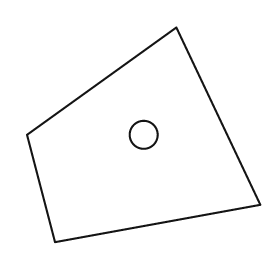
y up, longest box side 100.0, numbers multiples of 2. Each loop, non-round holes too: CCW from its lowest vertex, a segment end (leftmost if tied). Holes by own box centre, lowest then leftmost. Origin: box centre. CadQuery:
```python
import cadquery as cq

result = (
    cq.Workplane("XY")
    .moveTo(-38.0, -46.0)
    .lineTo(50.0, -30.0)
    .lineTo(14.0, 46.0)
    .lineTo(-50.0, 0.0)
    .close()
    .moveTo(0.0, 0.0)
    .circle(6.0)
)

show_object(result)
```